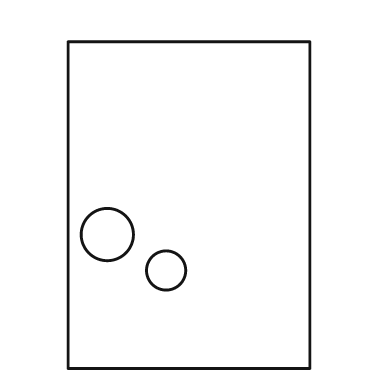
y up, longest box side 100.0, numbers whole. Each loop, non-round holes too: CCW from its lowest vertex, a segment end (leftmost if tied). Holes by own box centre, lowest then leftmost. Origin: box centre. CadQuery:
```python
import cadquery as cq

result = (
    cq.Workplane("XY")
    .moveTo(-37.0, -50.0)
    .lineTo(37.0, -50.0)
    .lineTo(37.0, 50.0)
    .lineTo(-37.0, 50.0)
    .close()
    .moveTo(-7.0, -20.0)
    .circle(6.0)
    .moveTo(-25.0, -9.0)
    .circle(8.0)
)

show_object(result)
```